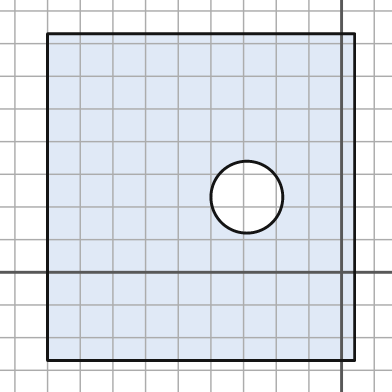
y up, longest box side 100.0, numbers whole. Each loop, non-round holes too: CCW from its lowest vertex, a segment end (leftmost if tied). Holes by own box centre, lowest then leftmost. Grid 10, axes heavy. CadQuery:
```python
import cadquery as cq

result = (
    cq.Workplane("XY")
    .moveTo(-90.0, -27.0)
    .lineTo(4.0, -27.0)
    .lineTo(4.0, 73.0)
    .lineTo(-90.0, 73.0)
    .close()
    .moveTo(-29.0, 23.0)
    .circle(11.0)
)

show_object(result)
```